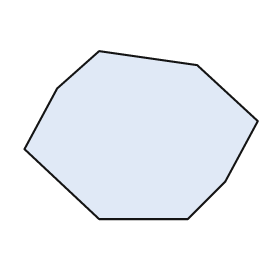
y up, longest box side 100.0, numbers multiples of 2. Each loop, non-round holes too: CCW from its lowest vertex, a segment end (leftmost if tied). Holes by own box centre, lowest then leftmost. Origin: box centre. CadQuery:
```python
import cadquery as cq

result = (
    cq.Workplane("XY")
    .moveTo(-18.0, -36.0)
    .lineTo(20.0, -36.0)
    .lineTo(36.0, -20.0)
    .lineTo(50.0, 6.0)
    .lineTo(24.0, 30.0)
    .lineTo(-18.0, 36.0)
    .lineTo(-36.0, 20.0)
    .lineTo(-50.0, -6.0)
    .close()
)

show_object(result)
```